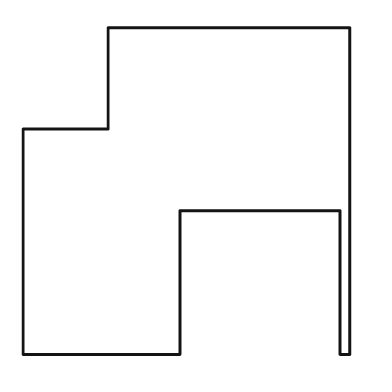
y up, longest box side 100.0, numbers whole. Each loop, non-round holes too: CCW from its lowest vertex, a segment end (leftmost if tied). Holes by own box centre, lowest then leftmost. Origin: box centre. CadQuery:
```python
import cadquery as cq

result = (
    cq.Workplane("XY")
    .moveTo(-50.0, -50.0)
    .lineTo(-2.0, -50.0)
    .lineTo(-2.0, -6.0)
    .lineTo(47.0, -6.0)
    .lineTo(47.0, -50.0)
    .lineTo(50.0, -50.0)
    .lineTo(50.0, 50.0)
    .lineTo(-24.0, 50.0)
    .lineTo(-24.0, 19.0)
    .lineTo(-50.0, 19.0)
    .close()
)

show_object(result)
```